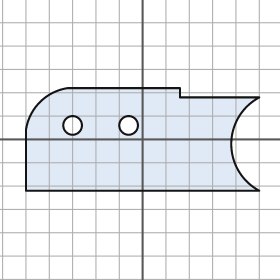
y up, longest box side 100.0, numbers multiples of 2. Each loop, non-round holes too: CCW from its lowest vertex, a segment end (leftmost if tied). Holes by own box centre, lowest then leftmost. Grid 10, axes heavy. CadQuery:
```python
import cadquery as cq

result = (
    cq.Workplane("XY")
    .moveTo(-50.0, -22.0)
    .lineTo(50.0, -22.0)
    .threePointArc((38.0, -2.0), (50.0, 18.0))
    .lineTo(16.0, 18.0)
    .lineTo(16.0, 22.0)
    .lineTo(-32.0, 22.0)
    .threePointArc((-44.0, 16.0), (-50.0, 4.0))
    .close()
    .moveTo(-30.0, 6.0)
    .circle(4.0)
    .moveTo(-6.0, 6.0)
    .circle(4.0)
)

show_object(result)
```